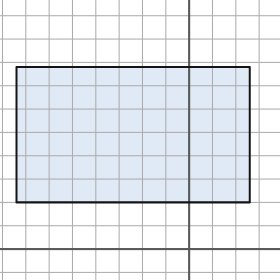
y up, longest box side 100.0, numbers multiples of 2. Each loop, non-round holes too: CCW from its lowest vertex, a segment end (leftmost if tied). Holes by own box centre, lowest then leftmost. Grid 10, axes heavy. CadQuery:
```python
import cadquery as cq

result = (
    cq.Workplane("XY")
    .moveTo(-74.0, 20.0)
    .lineTo(26.0, 20.0)
    .lineTo(26.0, 78.0)
    .lineTo(-74.0, 78.0)
    .close()
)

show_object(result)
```